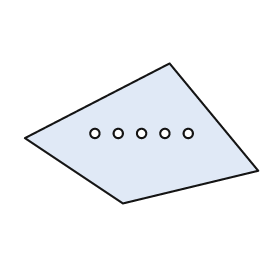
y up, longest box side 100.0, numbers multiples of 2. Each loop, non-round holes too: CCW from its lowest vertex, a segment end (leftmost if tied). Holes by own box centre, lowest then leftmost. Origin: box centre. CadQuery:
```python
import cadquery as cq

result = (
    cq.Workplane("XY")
    .moveTo(-8.0, -30.0)
    .lineTo(50.0, -16.0)
    .lineTo(12.0, 30.0)
    .lineTo(-50.0, -2.0)
    .close()
    .moveTo(-20.0, 0.0)
    .circle(2.0)
    .moveTo(-10.0, 0.0)
    .circle(2.0)
    .moveTo(0.0, 0.0)
    .circle(2.0)
    .moveTo(10.0, 0.0)
    .circle(2.0)
    .moveTo(20.0, 0.0)
    .circle(2.0)
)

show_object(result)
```